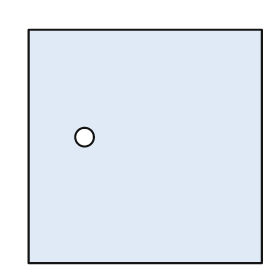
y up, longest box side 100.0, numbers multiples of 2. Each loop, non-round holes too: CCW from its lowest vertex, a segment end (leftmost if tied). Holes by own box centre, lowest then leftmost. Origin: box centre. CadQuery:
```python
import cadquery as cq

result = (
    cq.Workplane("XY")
    .moveTo(-50.0, -50.0)
    .lineTo(50.0, -50.0)
    .lineTo(50.0, 50.0)
    .lineTo(-50.0, 50.0)
    .close()
    .moveTo(-26.0, 4.0)
    .circle(4.0)
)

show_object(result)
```